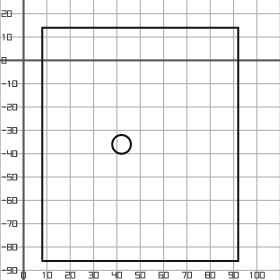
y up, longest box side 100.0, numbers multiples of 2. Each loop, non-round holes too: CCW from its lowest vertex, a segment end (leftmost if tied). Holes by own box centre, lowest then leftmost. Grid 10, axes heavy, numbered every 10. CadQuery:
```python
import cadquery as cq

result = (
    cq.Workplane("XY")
    .moveTo(8.0, -86.0)
    .lineTo(92.0, -86.0)
    .lineTo(92.0, 14.0)
    .lineTo(8.0, 14.0)
    .close()
    .moveTo(42.0, -36.0)
    .circle(4.0)
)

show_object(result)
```